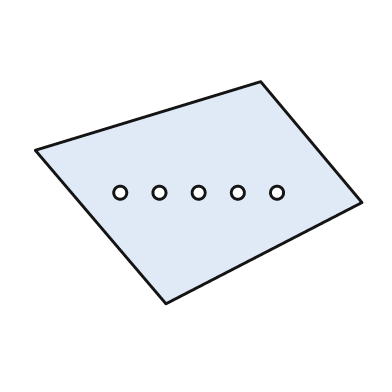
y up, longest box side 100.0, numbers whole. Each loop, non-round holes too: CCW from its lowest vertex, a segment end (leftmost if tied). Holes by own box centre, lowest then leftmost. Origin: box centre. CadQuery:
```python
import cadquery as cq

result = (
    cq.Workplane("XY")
    .moveTo(-10.0, -34.0)
    .lineTo(50.0, -3.0)
    .lineTo(19.0, 34.0)
    .lineTo(-50.0, 13.0)
    .close()
    .moveTo(-24.0, 0.0)
    .circle(2.0)
    .moveTo(-12.0, 0.0)
    .circle(2.0)
    .moveTo(0.0, 0.0)
    .circle(2.0)
    .moveTo(12.0, 0.0)
    .circle(2.0)
    .moveTo(24.0, 0.0)
    .circle(2.0)
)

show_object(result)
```